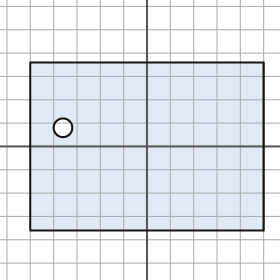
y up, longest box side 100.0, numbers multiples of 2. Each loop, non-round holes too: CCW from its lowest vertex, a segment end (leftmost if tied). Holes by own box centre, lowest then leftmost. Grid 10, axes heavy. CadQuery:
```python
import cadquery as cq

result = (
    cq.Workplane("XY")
    .moveTo(-50.0, -36.0)
    .lineTo(50.0, -36.0)
    .lineTo(50.0, 36.0)
    .lineTo(-50.0, 36.0)
    .close()
    .moveTo(-36.0, 8.0)
    .circle(4.0)
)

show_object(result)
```